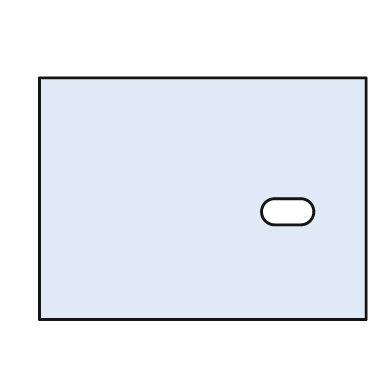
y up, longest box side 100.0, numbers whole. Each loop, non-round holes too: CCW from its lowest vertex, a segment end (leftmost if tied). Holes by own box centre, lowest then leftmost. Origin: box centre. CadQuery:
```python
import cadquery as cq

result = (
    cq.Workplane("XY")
    .moveTo(-50.0, -37.0)
    .lineTo(50.0, -37.0)
    .lineTo(50.0, 37.0)
    .lineTo(-50.0, 37.0)
    .close()
    .moveTo(22.0, -8.0)
    .lineTo(30.0, -8.0)
    .threePointArc((34.0, -4.0), (30.0, 0.0))
    .lineTo(22.0, 0.0)
    .threePointArc((18.0, -4.0), (22.0, -8.0))
    .close()
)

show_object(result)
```